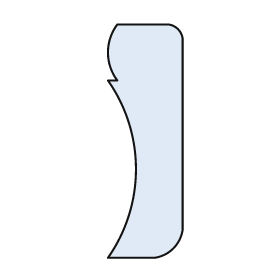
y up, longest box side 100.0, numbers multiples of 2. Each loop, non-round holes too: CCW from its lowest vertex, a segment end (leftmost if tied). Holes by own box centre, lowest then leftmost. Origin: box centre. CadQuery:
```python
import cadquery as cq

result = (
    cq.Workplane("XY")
    .moveTo(-16.0, -50.0)
    .lineTo(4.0, -50.0)
    .threePointArc((12.0, -46.0), (16.0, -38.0))
    .lineTo(16.0, 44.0)
    .threePointArc((14.0, 48.0), (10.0, 50.0))
    .lineTo(-12.0, 50.0)
    .threePointArc((-16.0, 38.0), (-12.0, 26.0))
    .lineTo(-16.0, 26.0)
    .threePointArc((-4.0, -12.0), (-16.0, -50.0))
    .close()
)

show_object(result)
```